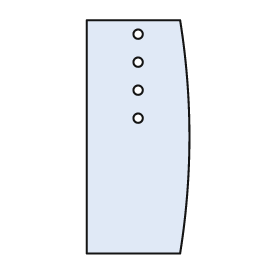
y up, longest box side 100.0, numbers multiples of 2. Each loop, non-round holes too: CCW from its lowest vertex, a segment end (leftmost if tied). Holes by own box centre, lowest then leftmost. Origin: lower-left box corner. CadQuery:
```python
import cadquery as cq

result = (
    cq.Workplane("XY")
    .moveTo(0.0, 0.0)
    .lineTo(40.0, 0.0)
    .threePointArc((44.0, 50.0), (40.0, 100.0))
    .lineTo(0.0, 100.0)
    .close()
    .moveTo(22.0, 58.0)
    .circle(2.0)
    .moveTo(22.0, 70.0)
    .circle(2.0)
    .moveTo(22.0, 82.0)
    .circle(2.0)
    .moveTo(22.0, 94.0)
    .circle(2.0)
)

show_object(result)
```